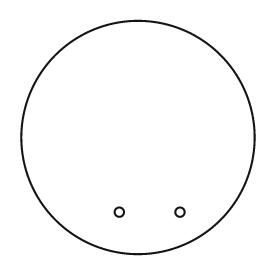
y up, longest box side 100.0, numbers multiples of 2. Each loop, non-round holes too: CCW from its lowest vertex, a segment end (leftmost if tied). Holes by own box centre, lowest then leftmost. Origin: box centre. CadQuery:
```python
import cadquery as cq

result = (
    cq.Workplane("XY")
    .moveTo(0.0, 0.0)
    .circle(50.0)
    .moveTo(-8.0, -32.0)
    .circle(2.0)
    .moveTo(18.0, -32.0)
    .circle(2.0)
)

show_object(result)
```